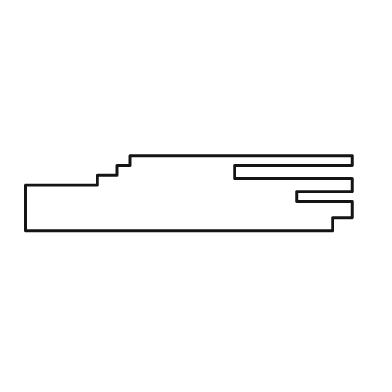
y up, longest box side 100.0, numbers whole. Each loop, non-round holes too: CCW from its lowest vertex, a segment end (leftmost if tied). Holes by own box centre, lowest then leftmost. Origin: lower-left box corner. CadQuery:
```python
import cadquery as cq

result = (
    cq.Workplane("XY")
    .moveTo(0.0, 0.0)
    .lineTo(94.0, 0.0)
    .lineTo(94.0, 4.0)
    .lineTo(100.0, 4.0)
    .lineTo(100.0, 9.0)
    .lineTo(83.0, 9.0)
    .lineTo(83.0, 12.0)
    .lineTo(100.0, 12.0)
    .lineTo(100.0, 16.0)
    .lineTo(64.0, 16.0)
    .lineTo(64.0, 20.0)
    .lineTo(100.0, 20.0)
    .lineTo(100.0, 23.0)
    .lineTo(32.0, 23.0)
    .lineTo(32.0, 20.0)
    .lineTo(28.0, 20.0)
    .lineTo(28.0, 17.0)
    .lineTo(22.0, 17.0)
    .lineTo(22.0, 14.0)
    .lineTo(0.0, 14.0)
    .close()
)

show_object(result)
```